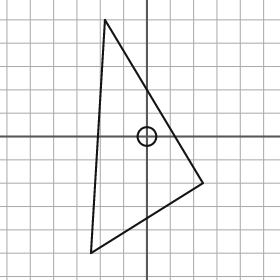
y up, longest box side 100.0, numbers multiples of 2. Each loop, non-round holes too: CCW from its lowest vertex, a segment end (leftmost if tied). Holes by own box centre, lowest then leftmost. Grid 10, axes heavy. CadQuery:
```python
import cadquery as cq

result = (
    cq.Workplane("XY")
    .moveTo(-24.0, -50.0)
    .lineTo(24.0, -20.0)
    .lineTo(-18.0, 50.0)
    .close()
    .moveTo(0.0, 0.0)
    .circle(4.0)
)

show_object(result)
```